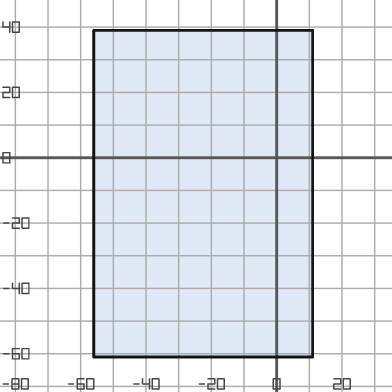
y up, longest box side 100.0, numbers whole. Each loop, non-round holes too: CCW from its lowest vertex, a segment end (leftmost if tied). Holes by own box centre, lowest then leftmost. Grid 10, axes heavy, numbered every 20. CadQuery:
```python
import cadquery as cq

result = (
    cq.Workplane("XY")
    .moveTo(-56.0, -61.0)
    .lineTo(11.0, -61.0)
    .lineTo(11.0, 39.0)
    .lineTo(-56.0, 39.0)
    .close()
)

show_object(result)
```